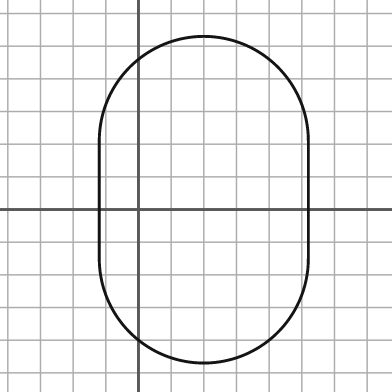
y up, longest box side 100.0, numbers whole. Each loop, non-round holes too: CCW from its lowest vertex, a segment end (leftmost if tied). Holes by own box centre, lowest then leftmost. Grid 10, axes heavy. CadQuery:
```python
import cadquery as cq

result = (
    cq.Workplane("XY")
    .moveTo(-12.0, -15.0)
    .threePointArc((20.0, -47.0), (52.0, -15.0))
    .lineTo(52.0, 21.0)
    .threePointArc((20.0, 53.0), (-12.0, 21.0))
    .close()
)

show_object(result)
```